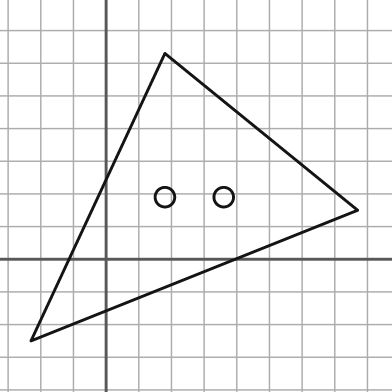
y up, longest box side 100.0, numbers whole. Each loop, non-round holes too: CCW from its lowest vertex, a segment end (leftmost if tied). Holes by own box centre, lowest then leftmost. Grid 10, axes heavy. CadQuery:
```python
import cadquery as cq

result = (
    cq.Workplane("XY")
    .moveTo(-23.0, -25.0)
    .lineTo(77.0, 15.0)
    .lineTo(18.0, 63.0)
    .close()
    .moveTo(18.0, 19.0)
    .circle(3.0)
    .moveTo(36.0, 19.0)
    .circle(3.0)
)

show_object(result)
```